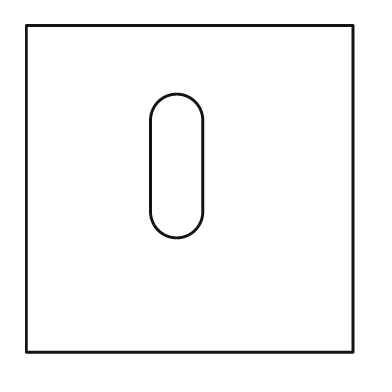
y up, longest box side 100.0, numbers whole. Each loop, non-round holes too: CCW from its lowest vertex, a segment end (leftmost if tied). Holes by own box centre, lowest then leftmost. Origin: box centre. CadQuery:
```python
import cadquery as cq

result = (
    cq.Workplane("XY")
    .moveTo(-50.0, -50.0)
    .lineTo(50.0, -50.0)
    .lineTo(50.0, 50.0)
    .lineTo(-50.0, 50.0)
    .close()
    .moveTo(-12.0, -7.0)
    .threePointArc((-4.0, -15.0), (4.0, -7.0))
    .lineTo(4.0, 21.0)
    .threePointArc((-4.0, 29.0), (-12.0, 21.0))
    .close()
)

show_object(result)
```